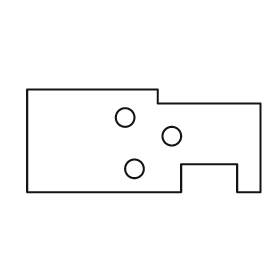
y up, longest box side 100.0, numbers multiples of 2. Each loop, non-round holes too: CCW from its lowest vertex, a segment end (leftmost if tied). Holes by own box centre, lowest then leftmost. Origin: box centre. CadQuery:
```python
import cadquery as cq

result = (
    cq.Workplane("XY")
    .moveTo(-50.0, -22.0)
    .lineTo(16.0, -22.0)
    .lineTo(16.0, -10.0)
    .lineTo(40.0, -10.0)
    .lineTo(40.0, -22.0)
    .lineTo(50.0, -22.0)
    .lineTo(50.0, 16.0)
    .lineTo(6.0, 16.0)
    .lineTo(6.0, 22.0)
    .lineTo(-50.0, 22.0)
    .close()
    .moveTo(-4.0, -12.0)
    .circle(4.0)
    .moveTo(12.0, 2.0)
    .circle(4.0)
    .moveTo(-8.0, 10.0)
    .circle(4.0)
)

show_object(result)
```